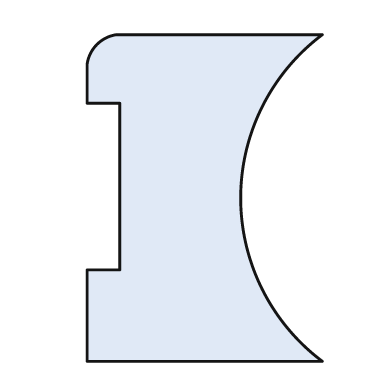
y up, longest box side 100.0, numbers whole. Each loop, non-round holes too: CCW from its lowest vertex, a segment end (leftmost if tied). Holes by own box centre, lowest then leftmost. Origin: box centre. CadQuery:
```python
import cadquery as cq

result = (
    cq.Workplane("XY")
    .moveTo(-36.0, -50.0)
    .lineTo(36.0, -50.0)
    .threePointArc((11.0, 0.0), (36.0, 50.0))
    .lineTo(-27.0, 50.0)
    .threePointArc((-33.0, 47.0), (-36.0, 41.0))
    .lineTo(-36.0, 29.0)
    .lineTo(-26.0, 29.0)
    .lineTo(-26.0, -22.0)
    .lineTo(-36.0, -22.0)
    .close()
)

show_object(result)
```